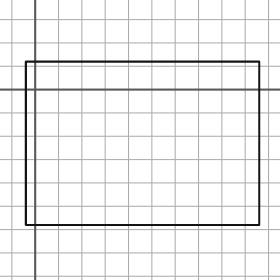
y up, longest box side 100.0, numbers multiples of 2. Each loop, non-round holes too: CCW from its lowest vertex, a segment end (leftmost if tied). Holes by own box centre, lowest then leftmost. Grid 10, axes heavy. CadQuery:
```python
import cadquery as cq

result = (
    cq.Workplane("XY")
    .moveTo(-4.0, -58.0)
    .lineTo(96.0, -58.0)
    .lineTo(96.0, 12.0)
    .lineTo(-4.0, 12.0)
    .close()
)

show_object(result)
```